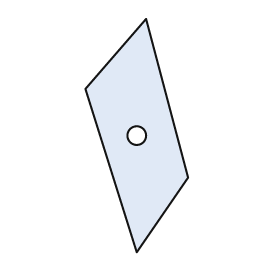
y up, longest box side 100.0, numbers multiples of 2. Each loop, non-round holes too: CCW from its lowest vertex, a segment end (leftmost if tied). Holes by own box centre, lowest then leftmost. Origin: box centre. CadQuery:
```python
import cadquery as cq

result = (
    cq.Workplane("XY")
    .moveTo(0.0, -50.0)
    .lineTo(22.0, -18.0)
    .lineTo(4.0, 50.0)
    .lineTo(-22.0, 20.0)
    .close()
    .moveTo(0.0, 0.0)
    .circle(4.0)
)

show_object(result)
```